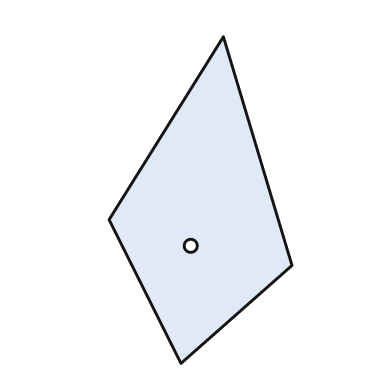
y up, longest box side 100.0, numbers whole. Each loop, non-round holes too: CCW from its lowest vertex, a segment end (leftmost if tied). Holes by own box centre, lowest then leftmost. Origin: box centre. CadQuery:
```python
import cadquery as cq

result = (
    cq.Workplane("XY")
    .moveTo(-6.0, -50.0)
    .lineTo(28.0, -20.0)
    .lineTo(7.0, 50.0)
    .lineTo(-28.0, -6.0)
    .close()
    .moveTo(-3.0, -14.0)
    .circle(2.0)
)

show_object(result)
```